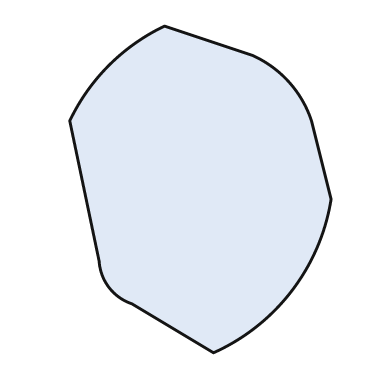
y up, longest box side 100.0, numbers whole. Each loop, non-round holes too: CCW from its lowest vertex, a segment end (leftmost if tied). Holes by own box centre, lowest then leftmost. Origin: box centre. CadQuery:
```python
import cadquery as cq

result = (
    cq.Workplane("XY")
    .moveTo(4.0, -50.0)
    .threePointArc((28.0, -31.0), (40.0, -3.0))
    .lineTo(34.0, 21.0)
    .threePointArc((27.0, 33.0), (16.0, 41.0))
    .lineTo(-11.0, 50.0)
    .threePointArc((-28.0, 38.0), (-40.0, 21.0))
    .lineTo(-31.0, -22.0)
    .threePointArc((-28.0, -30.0), (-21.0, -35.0))
    .close()
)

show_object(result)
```